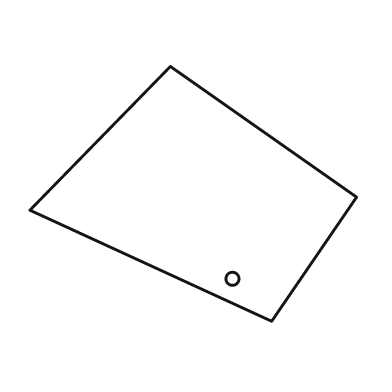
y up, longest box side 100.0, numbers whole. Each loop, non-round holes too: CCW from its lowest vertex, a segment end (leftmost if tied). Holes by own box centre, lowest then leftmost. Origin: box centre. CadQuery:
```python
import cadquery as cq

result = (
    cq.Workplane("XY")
    .moveTo(24.0, -39.0)
    .lineTo(50.0, -1.0)
    .lineTo(-7.0, 39.0)
    .lineTo(-50.0, -5.0)
    .close()
    .moveTo(12.0, -26.0)
    .circle(2.0)
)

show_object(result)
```